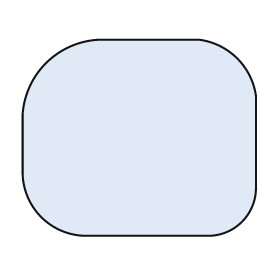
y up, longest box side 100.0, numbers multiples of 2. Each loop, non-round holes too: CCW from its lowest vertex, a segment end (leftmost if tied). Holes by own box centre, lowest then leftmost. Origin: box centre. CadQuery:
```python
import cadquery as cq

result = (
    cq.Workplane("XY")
    .moveTo(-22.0, -42.0)
    .lineTo(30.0, -42.0)
    .threePointArc((44.0, -36.0), (50.0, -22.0))
    .lineTo(50.0, 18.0)
    .threePointArc((42.0, 34.0), (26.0, 42.0))
    .lineTo(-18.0, 42.0)
    .threePointArc((-40.0, 32.0), (-50.0, 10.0))
    .lineTo(-50.0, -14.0)
    .threePointArc((-42.0, -34.0), (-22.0, -42.0))
    .close()
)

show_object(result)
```